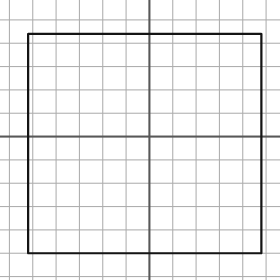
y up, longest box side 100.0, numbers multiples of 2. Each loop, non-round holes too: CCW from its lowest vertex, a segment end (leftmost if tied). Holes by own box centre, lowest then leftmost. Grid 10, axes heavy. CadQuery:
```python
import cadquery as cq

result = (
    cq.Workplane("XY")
    .moveTo(-52.0, -50.0)
    .lineTo(48.0, -50.0)
    .lineTo(48.0, 44.0)
    .lineTo(-52.0, 44.0)
    .close()
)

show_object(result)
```